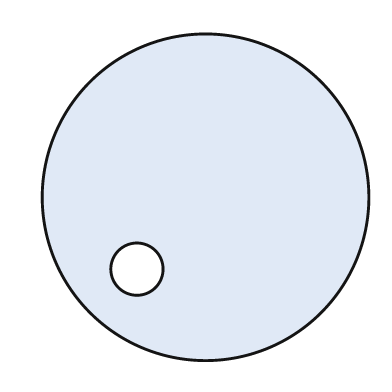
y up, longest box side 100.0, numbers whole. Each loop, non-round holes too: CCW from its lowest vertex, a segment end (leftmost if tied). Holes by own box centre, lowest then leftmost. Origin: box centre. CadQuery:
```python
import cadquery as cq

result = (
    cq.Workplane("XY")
    .moveTo(0.0, 0.0)
    .circle(50.0)
    .moveTo(-21.0, -22.0)
    .circle(8.0)
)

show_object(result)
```